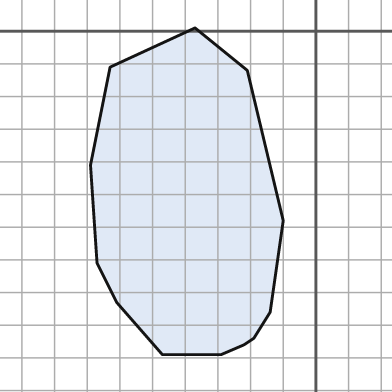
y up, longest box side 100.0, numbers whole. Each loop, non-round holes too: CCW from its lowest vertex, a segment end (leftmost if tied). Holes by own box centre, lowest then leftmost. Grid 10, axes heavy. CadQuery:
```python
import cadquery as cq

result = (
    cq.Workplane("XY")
    .moveTo(-47.0, -99.0)
    .lineTo(-29.0, -99.0)
    .lineTo(-22.0, -96.0)
    .lineTo(-19.0, -94.0)
    .lineTo(-14.0, -86.0)
    .lineTo(-10.0, -58.0)
    .lineTo(-21.0, -12.0)
    .lineTo(-37.0, 1.0)
    .lineTo(-63.0, -11.0)
    .lineTo(-69.0, -41.0)
    .lineTo(-67.0, -71.0)
    .lineTo(-61.0, -83.0)
    .close()
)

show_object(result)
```